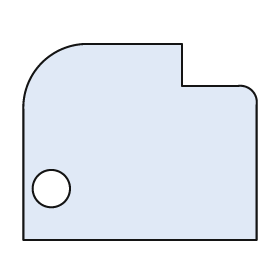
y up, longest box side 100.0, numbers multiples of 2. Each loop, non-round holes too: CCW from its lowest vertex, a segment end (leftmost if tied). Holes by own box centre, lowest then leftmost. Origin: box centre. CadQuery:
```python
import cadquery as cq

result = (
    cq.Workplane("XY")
    .moveTo(-50.0, -42.0)
    .lineTo(50.0, -42.0)
    .lineTo(50.0, 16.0)
    .threePointArc((48.0, 22.0), (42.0, 24.0))
    .lineTo(18.0, 24.0)
    .lineTo(18.0, 42.0)
    .lineTo(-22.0, 42.0)
    .threePointArc((-42.0, 34.0), (-50.0, 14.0))
    .close()
    .moveTo(-38.0, -20.0)
    .circle(8.0)
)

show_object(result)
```